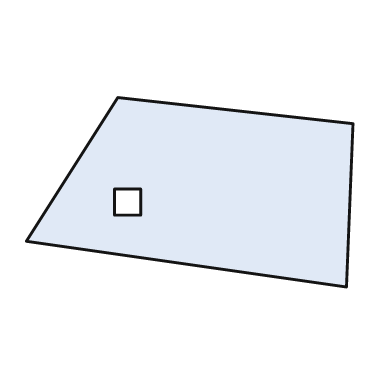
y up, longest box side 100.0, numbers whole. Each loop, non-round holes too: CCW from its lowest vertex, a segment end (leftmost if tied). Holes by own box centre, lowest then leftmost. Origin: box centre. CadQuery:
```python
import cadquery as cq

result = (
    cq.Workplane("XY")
    .moveTo(48.0, -29.0)
    .lineTo(50.0, 21.0)
    .lineTo(-22.0, 29.0)
    .lineTo(-50.0, -15.0)
    .close()
    .moveTo(-23.0, -7.0)
    .lineTo(-15.0, -7.0)
    .lineTo(-15.0, 1.0)
    .lineTo(-23.0, 1.0)
    .close()
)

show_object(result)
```